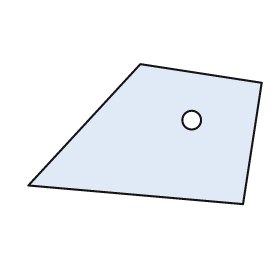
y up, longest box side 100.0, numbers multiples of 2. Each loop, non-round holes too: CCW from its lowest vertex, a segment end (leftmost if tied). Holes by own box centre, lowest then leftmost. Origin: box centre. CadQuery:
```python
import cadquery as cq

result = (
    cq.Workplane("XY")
    .moveTo(42.0, -30.0)
    .lineTo(50.0, 22.0)
    .lineTo(-2.0, 30.0)
    .lineTo(-50.0, -22.0)
    .close()
    .moveTo(20.0, 6.0)
    .circle(4.0)
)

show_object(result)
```